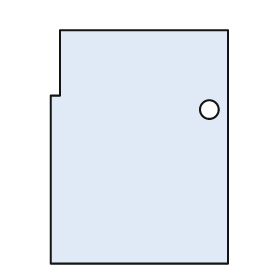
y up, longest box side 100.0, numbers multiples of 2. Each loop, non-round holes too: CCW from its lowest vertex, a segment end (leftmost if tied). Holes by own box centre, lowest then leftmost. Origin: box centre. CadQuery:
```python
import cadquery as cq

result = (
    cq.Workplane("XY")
    .moveTo(-38.0, -50.0)
    .lineTo(38.0, -50.0)
    .lineTo(38.0, 50.0)
    .lineTo(-34.0, 50.0)
    .lineTo(-34.0, 22.0)
    .lineTo(-38.0, 22.0)
    .close()
    .moveTo(30.0, 16.0)
    .circle(4.0)
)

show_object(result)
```